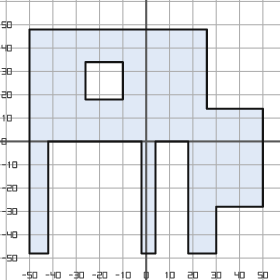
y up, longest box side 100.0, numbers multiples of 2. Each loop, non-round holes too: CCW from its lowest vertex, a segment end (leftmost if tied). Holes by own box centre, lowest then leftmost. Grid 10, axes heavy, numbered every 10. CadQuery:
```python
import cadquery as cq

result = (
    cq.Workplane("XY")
    .moveTo(-50.0, -48.0)
    .lineTo(-42.0, -48.0)
    .lineTo(-42.0, 0.0)
    .lineTo(-2.0, 0.0)
    .lineTo(-2.0, -48.0)
    .lineTo(4.0, -48.0)
    .lineTo(4.0, 0.0)
    .lineTo(18.0, 0.0)
    .lineTo(18.0, -48.0)
    .lineTo(30.0, -48.0)
    .lineTo(30.0, -28.0)
    .lineTo(50.0, -28.0)
    .lineTo(50.0, 14.0)
    .lineTo(26.0, 14.0)
    .lineTo(26.0, 48.0)
    .lineTo(-50.0, 48.0)
    .close()
    .moveTo(-26.0, 18.0)
    .lineTo(-10.0, 18.0)
    .lineTo(-10.0, 34.0)
    .lineTo(-26.0, 34.0)
    .close()
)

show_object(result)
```